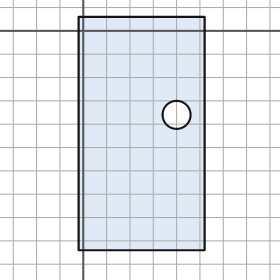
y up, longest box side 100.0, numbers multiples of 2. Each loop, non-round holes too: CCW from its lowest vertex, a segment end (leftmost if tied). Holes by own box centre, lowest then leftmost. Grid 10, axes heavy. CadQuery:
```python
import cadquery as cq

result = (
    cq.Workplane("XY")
    .moveTo(-2.0, -94.0)
    .lineTo(52.0, -94.0)
    .lineTo(52.0, 6.0)
    .lineTo(-2.0, 6.0)
    .close()
    .moveTo(40.0, -36.0)
    .circle(6.0)
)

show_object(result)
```